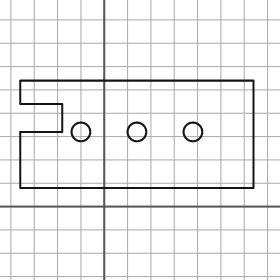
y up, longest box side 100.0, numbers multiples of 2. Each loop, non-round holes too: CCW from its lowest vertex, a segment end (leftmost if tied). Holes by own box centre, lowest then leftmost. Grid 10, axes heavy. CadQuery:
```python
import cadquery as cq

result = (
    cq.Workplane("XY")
    .moveTo(-36.0, 8.0)
    .lineTo(64.0, 8.0)
    .lineTo(64.0, 54.0)
    .lineTo(-36.0, 54.0)
    .lineTo(-36.0, 44.0)
    .lineTo(-18.0, 44.0)
    .lineTo(-18.0, 32.0)
    .lineTo(-36.0, 32.0)
    .close()
    .moveTo(-10.0, 32.0)
    .circle(4.0)
    .moveTo(14.0, 32.0)
    .circle(4.0)
    .moveTo(38.0, 32.0)
    .circle(4.0)
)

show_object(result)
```